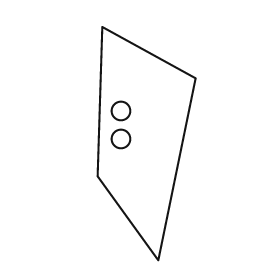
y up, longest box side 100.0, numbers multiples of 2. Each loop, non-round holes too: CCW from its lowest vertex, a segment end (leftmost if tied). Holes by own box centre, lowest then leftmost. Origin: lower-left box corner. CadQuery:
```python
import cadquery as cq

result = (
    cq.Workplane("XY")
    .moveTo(26.0, 0.0)
    .lineTo(42.0, 78.0)
    .lineTo(2.0, 100.0)
    .lineTo(0.0, 36.0)
    .close()
    .moveTo(10.0, 52.0)
    .circle(4.0)
    .moveTo(10.0, 64.0)
    .circle(4.0)
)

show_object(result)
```